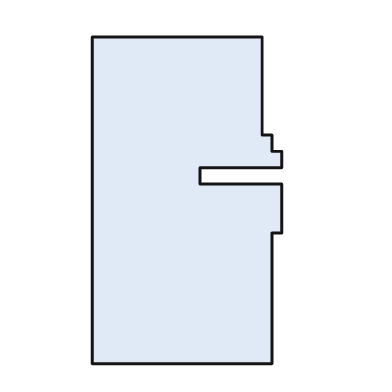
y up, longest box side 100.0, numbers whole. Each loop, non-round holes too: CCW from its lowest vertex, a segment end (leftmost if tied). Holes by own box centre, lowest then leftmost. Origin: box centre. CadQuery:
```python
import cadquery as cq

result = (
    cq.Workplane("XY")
    .moveTo(-29.0, -50.0)
    .lineTo(26.0, -50.0)
    .lineTo(26.0, -10.0)
    .lineTo(29.0, -10.0)
    .lineTo(29.0, 5.0)
    .lineTo(4.0, 5.0)
    .lineTo(4.0, 10.0)
    .lineTo(29.0, 10.0)
    .lineTo(29.0, 15.0)
    .lineTo(26.0, 15.0)
    .lineTo(26.0, 20.0)
    .lineTo(23.0, 20.0)
    .lineTo(23.0, 50.0)
    .lineTo(-29.0, 50.0)
    .close()
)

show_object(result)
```